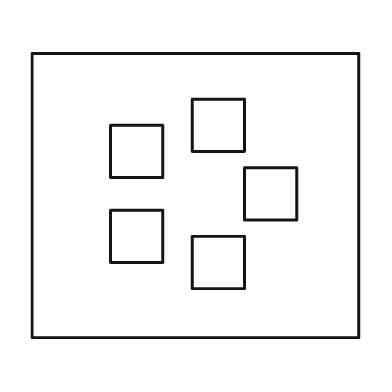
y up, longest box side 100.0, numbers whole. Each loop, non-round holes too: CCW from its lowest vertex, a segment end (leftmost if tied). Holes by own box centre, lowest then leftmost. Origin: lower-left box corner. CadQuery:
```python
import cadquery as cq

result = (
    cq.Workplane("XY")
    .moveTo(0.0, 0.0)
    .lineTo(100.0, 0.0)
    .lineTo(100.0, 87.0)
    .lineTo(0.0, 87.0)
    .close()
    .moveTo(49.0, 15.0)
    .lineTo(65.0, 15.0)
    .lineTo(65.0, 31.0)
    .lineTo(49.0, 31.0)
    .close()
    .moveTo(24.0, 23.0)
    .lineTo(40.0, 23.0)
    .lineTo(40.0, 39.0)
    .lineTo(24.0, 39.0)
    .close()
    .moveTo(65.0, 36.0)
    .lineTo(81.0, 36.0)
    .lineTo(81.0, 52.0)
    .lineTo(65.0, 52.0)
    .close()
    .moveTo(24.0, 49.0)
    .lineTo(40.0, 49.0)
    .lineTo(40.0, 65.0)
    .lineTo(24.0, 65.0)
    .close()
    .moveTo(49.0, 57.0)
    .lineTo(65.0, 57.0)
    .lineTo(65.0, 73.0)
    .lineTo(49.0, 73.0)
    .close()
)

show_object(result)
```